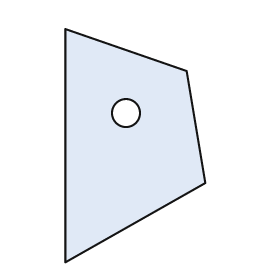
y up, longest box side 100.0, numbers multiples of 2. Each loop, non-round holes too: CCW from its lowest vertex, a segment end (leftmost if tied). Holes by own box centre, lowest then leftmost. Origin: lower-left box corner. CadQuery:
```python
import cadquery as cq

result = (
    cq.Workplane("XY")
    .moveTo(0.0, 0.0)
    .lineTo(60.0, 34.0)
    .lineTo(52.0, 82.0)
    .lineTo(0.0, 100.0)
    .close()
    .moveTo(26.0, 64.0)
    .circle(6.0)
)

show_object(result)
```